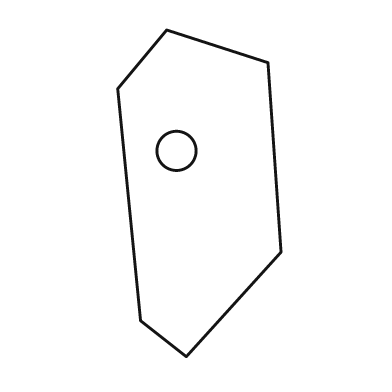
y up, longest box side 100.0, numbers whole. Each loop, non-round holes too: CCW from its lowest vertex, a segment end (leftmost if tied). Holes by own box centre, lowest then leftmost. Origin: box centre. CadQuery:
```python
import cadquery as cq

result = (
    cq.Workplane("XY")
    .moveTo(-4.0, -50.0)
    .lineTo(25.0, -18.0)
    .lineTo(21.0, 40.0)
    .lineTo(-10.0, 50.0)
    .lineTo(-25.0, 32.0)
    .lineTo(-18.0, -39.0)
    .close()
    .moveTo(-7.0, 13.0)
    .circle(6.0)
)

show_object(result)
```